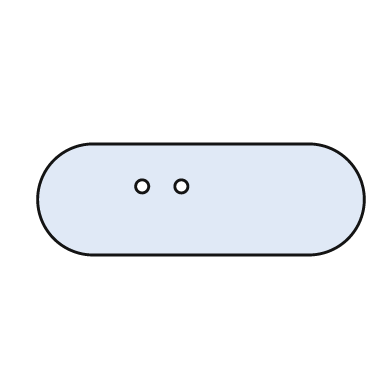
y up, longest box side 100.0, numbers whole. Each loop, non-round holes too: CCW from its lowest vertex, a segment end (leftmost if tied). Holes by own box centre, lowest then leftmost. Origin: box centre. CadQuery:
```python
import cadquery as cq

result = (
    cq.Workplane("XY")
    .moveTo(-33.0, -17.0)
    .lineTo(33.0, -17.0)
    .threePointArc((50.0, 0.0), (33.0, 17.0))
    .lineTo(-33.0, 17.0)
    .threePointArc((-50.0, 0.0), (-33.0, -17.0))
    .close()
    .moveTo(-18.0, 4.0)
    .circle(2.0)
    .moveTo(-6.0, 4.0)
    .circle(2.0)
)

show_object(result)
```